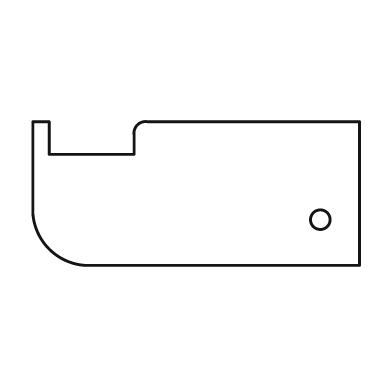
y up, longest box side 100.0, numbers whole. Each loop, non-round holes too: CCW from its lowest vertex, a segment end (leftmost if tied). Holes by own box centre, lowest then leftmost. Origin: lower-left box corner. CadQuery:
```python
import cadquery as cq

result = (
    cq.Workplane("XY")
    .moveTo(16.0, 0.0)
    .lineTo(100.0, 0.0)
    .lineTo(100.0, 44.0)
    .lineTo(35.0, 44.0)
    .threePointArc((32.0, 43.0), (31.0, 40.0))
    .lineTo(31.0, 34.0)
    .lineTo(5.0, 34.0)
    .lineTo(5.0, 44.0)
    .lineTo(0.0, 44.0)
    .lineTo(0.0, 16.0)
    .threePointArc((5.0, 5.0), (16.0, 0.0))
    .close()
    .moveTo(88.0, 14.0)
    .circle(3.0)
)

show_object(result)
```